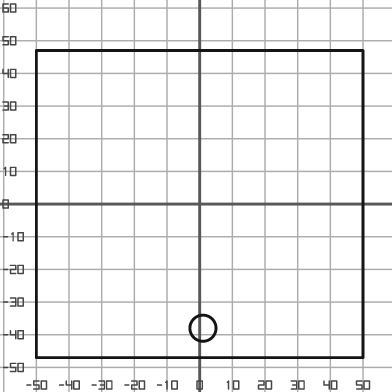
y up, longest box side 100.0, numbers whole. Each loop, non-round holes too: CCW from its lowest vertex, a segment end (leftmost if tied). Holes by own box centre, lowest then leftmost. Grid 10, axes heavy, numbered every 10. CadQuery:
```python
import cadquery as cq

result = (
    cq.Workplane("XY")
    .moveTo(-50.0, -47.0)
    .lineTo(50.0, -47.0)
    .lineTo(50.0, 47.0)
    .lineTo(-50.0, 47.0)
    .close()
    .moveTo(1.0, -38.0)
    .circle(4.0)
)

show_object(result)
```